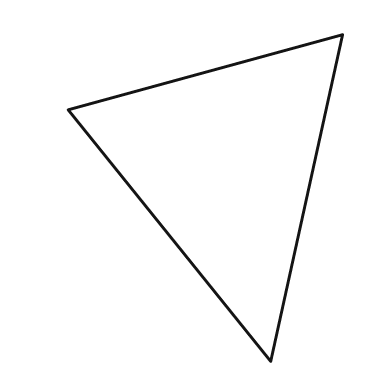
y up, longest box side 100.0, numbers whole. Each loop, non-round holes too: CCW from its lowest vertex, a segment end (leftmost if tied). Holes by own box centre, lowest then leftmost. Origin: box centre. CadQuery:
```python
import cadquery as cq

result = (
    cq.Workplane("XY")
    .moveTo(20.0, -50.0)
    .lineTo(42.0, 50.0)
    .lineTo(-42.0, 27.0)
    .close()
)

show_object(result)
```